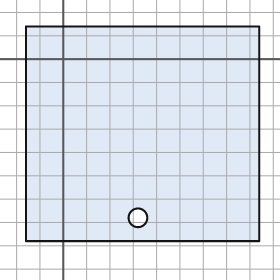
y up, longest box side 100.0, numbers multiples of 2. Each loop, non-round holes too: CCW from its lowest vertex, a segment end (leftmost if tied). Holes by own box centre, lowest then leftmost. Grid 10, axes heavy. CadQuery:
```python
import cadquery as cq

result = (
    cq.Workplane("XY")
    .moveTo(-16.0, -78.0)
    .lineTo(84.0, -78.0)
    .lineTo(84.0, 14.0)
    .lineTo(-16.0, 14.0)
    .close()
    .moveTo(32.0, -68.0)
    .circle(4.0)
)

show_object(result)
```